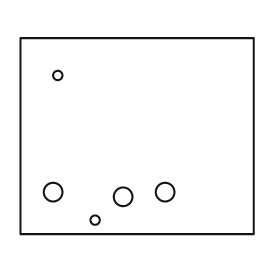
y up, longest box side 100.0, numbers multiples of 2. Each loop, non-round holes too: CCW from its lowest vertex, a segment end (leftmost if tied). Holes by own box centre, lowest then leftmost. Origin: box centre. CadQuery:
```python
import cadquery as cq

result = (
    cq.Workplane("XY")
    .moveTo(-50.0, -42.0)
    .lineTo(50.0, -42.0)
    .lineTo(50.0, 42.0)
    .lineTo(-50.0, 42.0)
    .close()
    .moveTo(-18.0, -36.0)
    .circle(2.0)
    .moveTo(-6.0, -26.0)
    .circle(4.0)
    .moveTo(-36.0, -24.0)
    .circle(4.0)
    .moveTo(12.0, -24.0)
    .circle(4.0)
    .moveTo(-34.0, 26.0)
    .circle(2.0)
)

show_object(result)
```